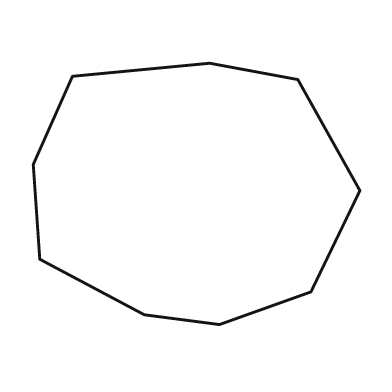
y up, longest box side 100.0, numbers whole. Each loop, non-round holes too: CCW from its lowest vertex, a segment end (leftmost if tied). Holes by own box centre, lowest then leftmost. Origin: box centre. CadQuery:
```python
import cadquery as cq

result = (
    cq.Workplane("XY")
    .moveTo(7.0, -40.0)
    .lineTo(35.0, -30.0)
    .lineTo(50.0, 1.0)
    .lineTo(31.0, 35.0)
    .lineTo(4.0, 40.0)
    .lineTo(-38.0, 36.0)
    .lineTo(-50.0, 9.0)
    .lineTo(-48.0, -20.0)
    .lineTo(-16.0, -37.0)
    .close()
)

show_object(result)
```